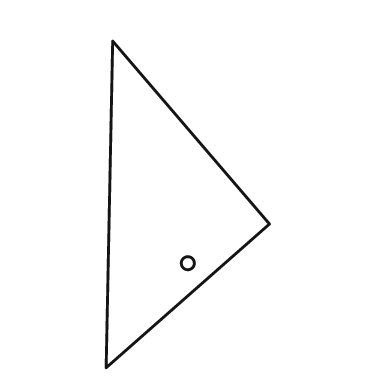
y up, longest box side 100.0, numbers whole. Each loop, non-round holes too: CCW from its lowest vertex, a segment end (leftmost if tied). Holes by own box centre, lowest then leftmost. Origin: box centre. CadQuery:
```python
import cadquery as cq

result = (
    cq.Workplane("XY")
    .moveTo(-25.0, -50.0)
    .lineTo(25.0, -6.0)
    .lineTo(-23.0, 50.0)
    .close()
    .moveTo(0.0, -18.0)
    .circle(2.0)
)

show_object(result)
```